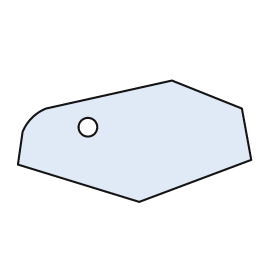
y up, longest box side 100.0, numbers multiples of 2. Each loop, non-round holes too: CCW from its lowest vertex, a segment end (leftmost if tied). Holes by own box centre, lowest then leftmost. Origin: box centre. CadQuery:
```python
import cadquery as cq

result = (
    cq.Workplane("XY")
    .moveTo(2.0, -26.0)
    .lineTo(50.0, -8.0)
    .lineTo(46.0, 14.0)
    .lineTo(16.0, 26.0)
    .lineTo(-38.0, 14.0)
    .threePointArc((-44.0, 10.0), (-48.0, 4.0))
    .lineTo(-50.0, -10.0)
    .close()
    .moveTo(-20.0, 6.0)
    .circle(4.0)
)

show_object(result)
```